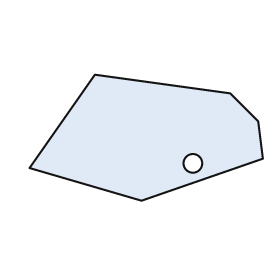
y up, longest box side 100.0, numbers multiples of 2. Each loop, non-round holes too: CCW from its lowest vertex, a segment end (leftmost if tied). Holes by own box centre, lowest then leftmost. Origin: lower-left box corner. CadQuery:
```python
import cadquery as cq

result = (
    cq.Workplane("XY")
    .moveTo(48.0, 0.0)
    .lineTo(100.0, 18.0)
    .lineTo(98.0, 34.0)
    .lineTo(86.0, 46.0)
    .lineTo(28.0, 54.0)
    .lineTo(0.0, 14.0)
    .close()
    .moveTo(70.0, 16.0)
    .circle(4.0)
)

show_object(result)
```